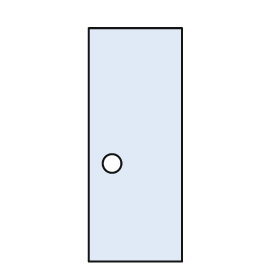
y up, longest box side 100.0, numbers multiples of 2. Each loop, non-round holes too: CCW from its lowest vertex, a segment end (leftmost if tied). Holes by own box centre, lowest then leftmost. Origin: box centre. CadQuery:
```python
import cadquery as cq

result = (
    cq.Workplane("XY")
    .moveTo(-20.0, -50.0)
    .lineTo(20.0, -50.0)
    .lineTo(20.0, 50.0)
    .lineTo(-20.0, 50.0)
    .close()
    .moveTo(-10.0, -8.0)
    .circle(4.0)
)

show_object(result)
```